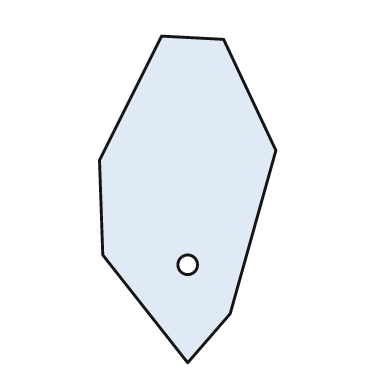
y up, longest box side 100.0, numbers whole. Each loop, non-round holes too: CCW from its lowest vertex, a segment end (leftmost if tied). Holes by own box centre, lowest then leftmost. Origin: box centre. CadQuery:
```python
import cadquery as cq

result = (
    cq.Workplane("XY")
    .moveTo(0.0, -50.0)
    .lineTo(13.0, -35.0)
    .lineTo(27.0, 15.0)
    .lineTo(11.0, 49.0)
    .lineTo(-8.0, 50.0)
    .lineTo(-27.0, 12.0)
    .lineTo(-26.0, -17.0)
    .close()
    .moveTo(0.0, -20.0)
    .circle(3.0)
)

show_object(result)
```